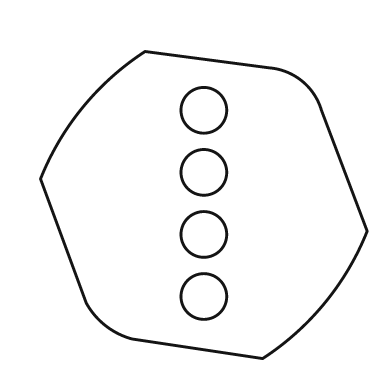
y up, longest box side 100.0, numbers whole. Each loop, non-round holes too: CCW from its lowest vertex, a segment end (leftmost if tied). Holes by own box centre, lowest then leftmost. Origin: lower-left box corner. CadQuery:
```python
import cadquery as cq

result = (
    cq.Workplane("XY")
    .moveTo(68.0, 0.0)
    .threePointArc((87.0, 17.0), (100.0, 39.0))
    .lineTo(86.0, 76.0)
    .threePointArc((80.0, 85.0), (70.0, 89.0))
    .lineTo(32.0, 94.0)
    .threePointArc((13.0, 77.0), (0.0, 55.0))
    .lineTo(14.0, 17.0)
    .threePointArc((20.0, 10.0), (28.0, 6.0))
    .close()
    .moveTo(50.0, 19.0)
    .circle(7.0)
    .moveTo(50.0, 38.0)
    .circle(7.0)
    .moveTo(50.0, 57.0)
    .circle(7.0)
    .moveTo(50.0, 76.0)
    .circle(7.0)
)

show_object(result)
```